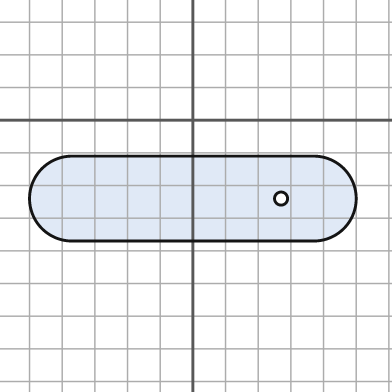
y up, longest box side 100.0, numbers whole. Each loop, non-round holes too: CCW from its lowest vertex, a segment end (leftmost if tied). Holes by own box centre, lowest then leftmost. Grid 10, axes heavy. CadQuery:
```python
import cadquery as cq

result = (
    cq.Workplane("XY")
    .moveTo(-37.0, -37.0)
    .lineTo(37.0, -37.0)
    .threePointArc((50.0, -24.0), (37.0, -11.0))
    .lineTo(-37.0, -11.0)
    .threePointArc((-50.0, -24.0), (-37.0, -37.0))
    .close()
    .moveTo(27.0, -24.0)
    .circle(2.0)
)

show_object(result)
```